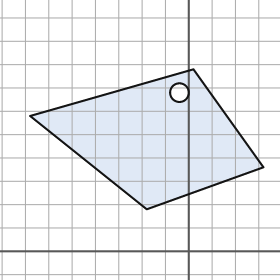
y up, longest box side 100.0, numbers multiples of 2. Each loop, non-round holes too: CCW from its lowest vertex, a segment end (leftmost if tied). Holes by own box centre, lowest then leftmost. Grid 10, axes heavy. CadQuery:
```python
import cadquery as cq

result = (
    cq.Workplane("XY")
    .moveTo(-18.0, 18.0)
    .lineTo(32.0, 36.0)
    .lineTo(2.0, 78.0)
    .lineTo(-68.0, 58.0)
    .close()
    .moveTo(-4.0, 68.0)
    .circle(4.0)
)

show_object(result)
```